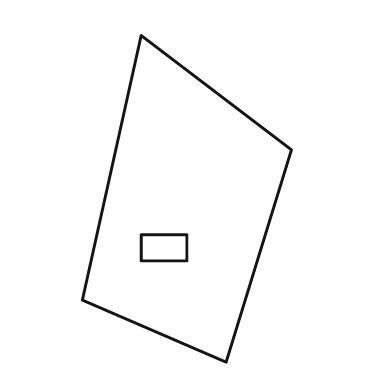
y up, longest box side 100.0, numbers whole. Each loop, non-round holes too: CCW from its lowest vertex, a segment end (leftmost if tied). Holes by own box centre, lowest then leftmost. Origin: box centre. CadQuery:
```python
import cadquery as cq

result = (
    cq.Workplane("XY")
    .moveTo(12.0, -50.0)
    .lineTo(32.0, 15.0)
    .lineTo(-14.0, 50.0)
    .lineTo(-32.0, -31.0)
    .close()
    .moveTo(-14.0, -19.0)
    .lineTo(0.0, -19.0)
    .lineTo(0.0, -11.0)
    .lineTo(-14.0, -11.0)
    .close()
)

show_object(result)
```